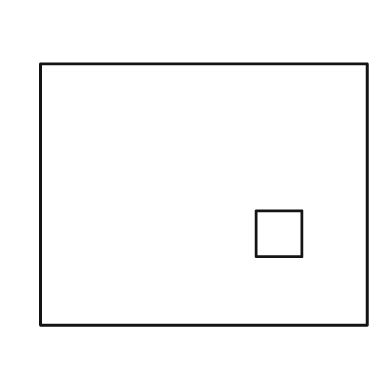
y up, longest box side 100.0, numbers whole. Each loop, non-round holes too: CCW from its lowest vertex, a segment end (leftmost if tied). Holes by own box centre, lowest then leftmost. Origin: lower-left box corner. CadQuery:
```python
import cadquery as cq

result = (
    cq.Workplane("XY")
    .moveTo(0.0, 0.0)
    .lineTo(100.0, 0.0)
    .lineTo(100.0, 80.0)
    .lineTo(0.0, 80.0)
    .close()
    .moveTo(66.0, 21.0)
    .lineTo(80.0, 21.0)
    .lineTo(80.0, 35.0)
    .lineTo(66.0, 35.0)
    .close()
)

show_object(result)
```